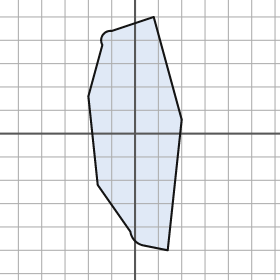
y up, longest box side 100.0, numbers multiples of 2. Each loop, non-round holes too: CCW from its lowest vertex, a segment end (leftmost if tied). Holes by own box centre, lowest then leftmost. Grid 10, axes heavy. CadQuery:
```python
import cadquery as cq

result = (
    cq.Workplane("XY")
    .moveTo(14.0, -50.0)
    .lineTo(20.0, 6.0)
    .lineTo(8.0, 50.0)
    .lineTo(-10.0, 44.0)
    .threePointArc((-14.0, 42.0), (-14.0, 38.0))
    .lineTo(-20.0, 16.0)
    .lineTo(-16.0, -22.0)
    .lineTo(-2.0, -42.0)
    .threePointArc((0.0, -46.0), (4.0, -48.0))
    .close()
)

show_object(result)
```